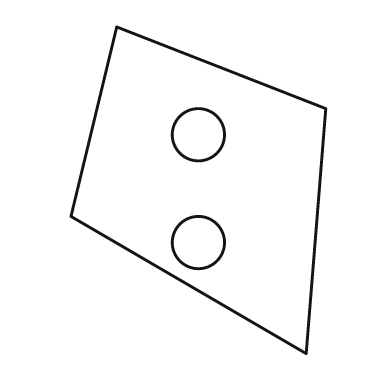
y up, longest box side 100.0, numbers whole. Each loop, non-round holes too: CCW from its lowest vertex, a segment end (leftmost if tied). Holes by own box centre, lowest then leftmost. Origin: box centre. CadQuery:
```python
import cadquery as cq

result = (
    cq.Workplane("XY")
    .moveTo(33.0, -50.0)
    .lineTo(39.0, 25.0)
    .lineTo(-25.0, 50.0)
    .lineTo(-39.0, -8.0)
    .close()
    .moveTo(0.0, -16.0)
    .circle(8.0)
    .moveTo(0.0, 17.0)
    .circle(8.0)
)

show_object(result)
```